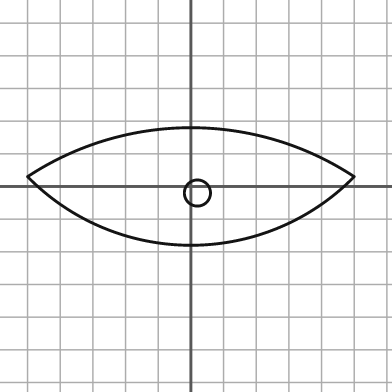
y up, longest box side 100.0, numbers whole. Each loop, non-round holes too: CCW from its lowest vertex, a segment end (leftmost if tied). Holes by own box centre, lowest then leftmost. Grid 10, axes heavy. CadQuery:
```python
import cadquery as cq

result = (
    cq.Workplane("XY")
    .moveTo(-50.0, 3.0)
    .threePointArc((0.0, -18.0), (50.0, 3.0))
    .threePointArc((0.0, 18.0), (-50.0, 3.0))
    .close()
    .moveTo(2.0, -2.0)
    .circle(4.0)
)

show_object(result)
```